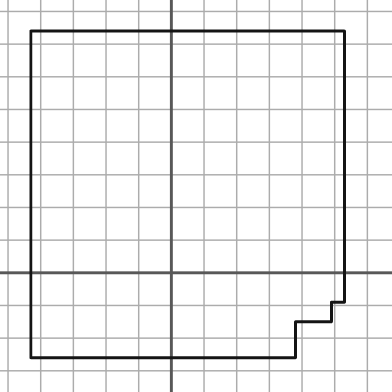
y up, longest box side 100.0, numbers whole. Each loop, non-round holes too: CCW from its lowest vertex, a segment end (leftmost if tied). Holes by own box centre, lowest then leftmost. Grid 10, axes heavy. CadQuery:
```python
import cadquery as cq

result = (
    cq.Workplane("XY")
    .moveTo(-43.0, -26.0)
    .lineTo(38.0, -26.0)
    .lineTo(38.0, -15.0)
    .lineTo(49.0, -15.0)
    .lineTo(49.0, -9.0)
    .lineTo(53.0, -9.0)
    .lineTo(53.0, 74.0)
    .lineTo(-43.0, 74.0)
    .close()
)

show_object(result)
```